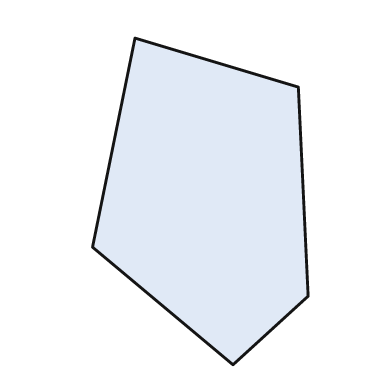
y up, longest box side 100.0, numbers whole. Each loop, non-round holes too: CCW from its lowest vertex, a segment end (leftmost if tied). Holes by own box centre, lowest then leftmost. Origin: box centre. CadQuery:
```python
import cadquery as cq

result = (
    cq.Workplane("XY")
    .moveTo(10.0, -50.0)
    .lineTo(33.0, -29.0)
    .lineTo(30.0, 35.0)
    .lineTo(-20.0, 50.0)
    .lineTo(-33.0, -14.0)
    .close()
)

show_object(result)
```